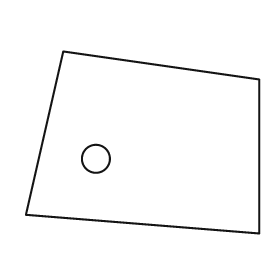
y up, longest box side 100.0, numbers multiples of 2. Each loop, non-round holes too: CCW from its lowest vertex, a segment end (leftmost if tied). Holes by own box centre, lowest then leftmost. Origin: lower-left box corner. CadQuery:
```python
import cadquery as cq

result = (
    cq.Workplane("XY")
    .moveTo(100.0, 0.0)
    .lineTo(100.0, 66.0)
    .lineTo(16.0, 78.0)
    .lineTo(0.0, 8.0)
    .close()
    .moveTo(30.0, 32.0)
    .circle(6.0)
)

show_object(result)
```